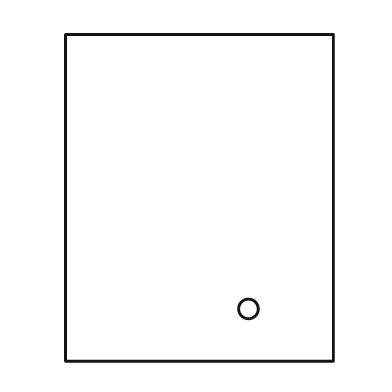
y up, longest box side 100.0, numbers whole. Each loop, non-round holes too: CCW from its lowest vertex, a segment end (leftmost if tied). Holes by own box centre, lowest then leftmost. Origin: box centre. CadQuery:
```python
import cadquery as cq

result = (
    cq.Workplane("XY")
    .moveTo(-41.0, -50.0)
    .lineTo(41.0, -50.0)
    .lineTo(41.0, 50.0)
    .lineTo(-41.0, 50.0)
    .close()
    .moveTo(15.0, -34.0)
    .circle(3.0)
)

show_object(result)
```